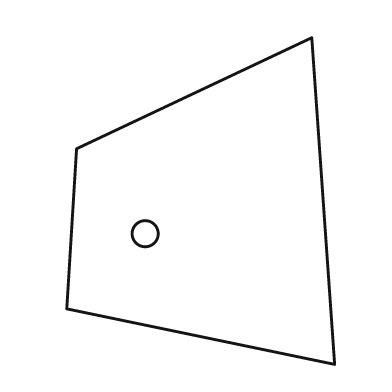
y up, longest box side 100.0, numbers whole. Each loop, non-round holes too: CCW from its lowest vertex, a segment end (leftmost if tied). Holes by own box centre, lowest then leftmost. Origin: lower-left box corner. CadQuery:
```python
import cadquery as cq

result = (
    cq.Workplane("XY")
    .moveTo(82.0, 0.0)
    .lineTo(75.0, 100.0)
    .lineTo(3.0, 66.0)
    .lineTo(0.0, 17.0)
    .close()
    .moveTo(24.0, 40.0)
    .circle(4.0)
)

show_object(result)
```